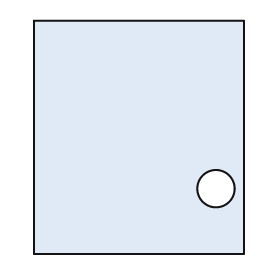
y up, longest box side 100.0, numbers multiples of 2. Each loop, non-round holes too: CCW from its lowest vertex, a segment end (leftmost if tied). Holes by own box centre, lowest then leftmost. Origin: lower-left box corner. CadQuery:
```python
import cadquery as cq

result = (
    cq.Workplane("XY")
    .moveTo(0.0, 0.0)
    .lineTo(90.0, 0.0)
    .lineTo(90.0, 100.0)
    .lineTo(0.0, 100.0)
    .close()
    .moveTo(78.0, 28.0)
    .circle(8.0)
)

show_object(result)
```